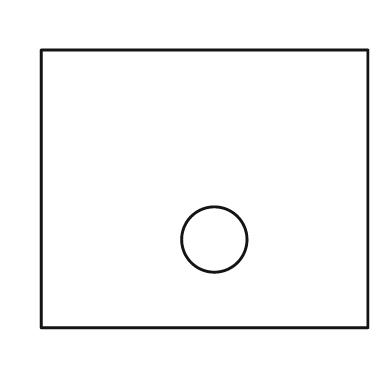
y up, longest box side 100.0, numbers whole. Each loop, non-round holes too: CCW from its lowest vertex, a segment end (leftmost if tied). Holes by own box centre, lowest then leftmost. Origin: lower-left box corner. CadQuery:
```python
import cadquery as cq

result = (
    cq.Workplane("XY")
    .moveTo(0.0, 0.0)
    .lineTo(100.0, 0.0)
    .lineTo(100.0, 85.0)
    .lineTo(0.0, 85.0)
    .close()
    .moveTo(53.0, 27.0)
    .circle(10.0)
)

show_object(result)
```